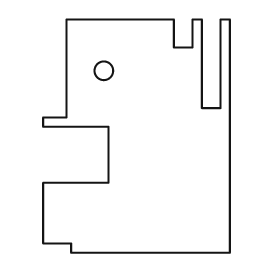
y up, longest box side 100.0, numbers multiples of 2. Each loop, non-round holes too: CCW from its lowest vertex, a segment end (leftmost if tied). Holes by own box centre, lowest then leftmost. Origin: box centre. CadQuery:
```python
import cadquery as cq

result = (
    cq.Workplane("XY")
    .moveTo(-28.0, -50.0)
    .lineTo(40.0, -50.0)
    .lineTo(40.0, 50.0)
    .lineTo(36.0, 50.0)
    .lineTo(36.0, 12.0)
    .lineTo(28.0, 12.0)
    .lineTo(28.0, 50.0)
    .lineTo(24.0, 50.0)
    .lineTo(24.0, 38.0)
    .lineTo(16.0, 38.0)
    .lineTo(16.0, 50.0)
    .lineTo(-30.0, 50.0)
    .lineTo(-30.0, 8.0)
    .lineTo(-40.0, 8.0)
    .lineTo(-40.0, 4.0)
    .lineTo(-12.0, 4.0)
    .lineTo(-12.0, -20.0)
    .lineTo(-40.0, -20.0)
    .lineTo(-40.0, -46.0)
    .lineTo(-28.0, -46.0)
    .close()
    .moveTo(-14.0, 28.0)
    .circle(4.0)
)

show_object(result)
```